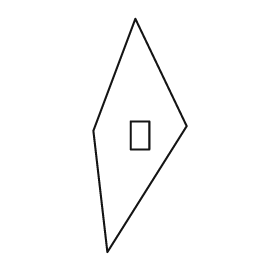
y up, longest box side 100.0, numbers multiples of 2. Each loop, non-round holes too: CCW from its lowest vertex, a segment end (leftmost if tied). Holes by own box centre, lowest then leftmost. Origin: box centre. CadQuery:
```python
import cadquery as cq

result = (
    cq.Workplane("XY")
    .moveTo(-14.0, -50.0)
    .lineTo(20.0, 4.0)
    .lineTo(-2.0, 50.0)
    .lineTo(-20.0, 2.0)
    .close()
    .moveTo(-4.0, -6.0)
    .lineTo(4.0, -6.0)
    .lineTo(4.0, 6.0)
    .lineTo(-4.0, 6.0)
    .close()
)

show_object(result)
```